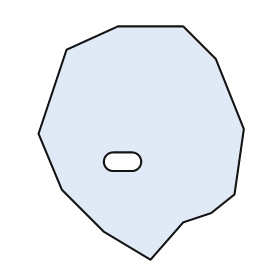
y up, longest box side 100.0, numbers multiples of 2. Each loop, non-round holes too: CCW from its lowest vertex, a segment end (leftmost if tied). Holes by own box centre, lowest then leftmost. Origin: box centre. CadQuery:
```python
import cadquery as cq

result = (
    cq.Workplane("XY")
    .moveTo(4.0, -50.0)
    .lineTo(18.0, -34.0)
    .lineTo(30.0, -30.0)
    .lineTo(40.0, -22.0)
    .lineTo(44.0, 6.0)
    .lineTo(32.0, 36.0)
    .lineTo(18.0, 50.0)
    .lineTo(-10.0, 50.0)
    .lineTo(-32.0, 40.0)
    .lineTo(-44.0, 4.0)
    .lineTo(-34.0, -20.0)
    .lineTo(-16.0, -38.0)
    .close()
    .moveTo(-12.0, -12.0)
    .lineTo(-4.0, -12.0)
    .threePointArc((0.0, -8.0), (-4.0, -4.0))
    .lineTo(-12.0, -4.0)
    .threePointArc((-16.0, -8.0), (-12.0, -12.0))
    .close()
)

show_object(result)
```